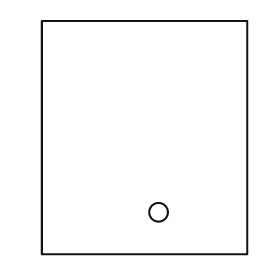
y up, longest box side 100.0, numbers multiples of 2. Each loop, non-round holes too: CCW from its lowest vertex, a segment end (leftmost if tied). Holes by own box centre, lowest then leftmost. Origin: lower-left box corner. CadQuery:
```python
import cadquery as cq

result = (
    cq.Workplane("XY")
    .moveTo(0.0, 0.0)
    .lineTo(88.0, 0.0)
    .lineTo(88.0, 100.0)
    .lineTo(0.0, 100.0)
    .close()
    .moveTo(50.0, 18.0)
    .circle(4.0)
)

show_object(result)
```